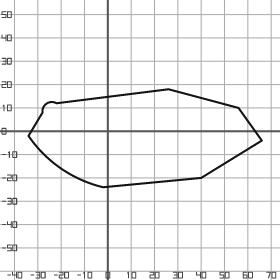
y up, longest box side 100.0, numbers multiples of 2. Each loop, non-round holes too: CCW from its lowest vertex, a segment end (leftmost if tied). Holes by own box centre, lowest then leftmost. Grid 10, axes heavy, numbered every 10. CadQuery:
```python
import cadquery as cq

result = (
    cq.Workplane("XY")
    .moveTo(-2.0, -24.0)
    .lineTo(40.0, -20.0)
    .lineTo(66.0, -4.0)
    .lineTo(56.0, 10.0)
    .lineTo(26.0, 18.0)
    .lineTo(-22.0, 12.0)
    .threePointArc((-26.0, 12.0), (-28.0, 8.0))
    .lineTo(-34.0, -2.0)
    .threePointArc((-20.0, -16.0), (-2.0, -24.0))
    .close()
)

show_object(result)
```